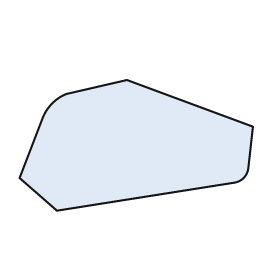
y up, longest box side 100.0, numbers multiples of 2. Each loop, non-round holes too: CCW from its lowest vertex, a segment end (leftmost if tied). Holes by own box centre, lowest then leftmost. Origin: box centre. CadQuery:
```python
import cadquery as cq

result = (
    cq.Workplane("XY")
    .moveTo(-34.0, -28.0)
    .lineTo(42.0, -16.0)
    .threePointArc((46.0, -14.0), (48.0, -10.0))
    .lineTo(50.0, 8.0)
    .lineTo(-4.0, 28.0)
    .lineTo(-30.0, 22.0)
    .threePointArc((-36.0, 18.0), (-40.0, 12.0))
    .lineTo(-50.0, -14.0)
    .close()
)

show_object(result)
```